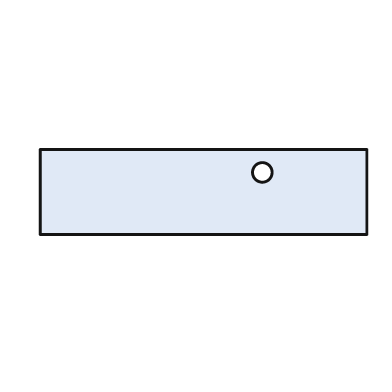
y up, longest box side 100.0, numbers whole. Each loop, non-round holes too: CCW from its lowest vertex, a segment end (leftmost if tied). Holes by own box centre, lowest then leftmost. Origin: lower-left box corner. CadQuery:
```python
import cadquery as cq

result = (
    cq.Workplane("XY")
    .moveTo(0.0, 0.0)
    .lineTo(100.0, 0.0)
    .lineTo(100.0, 26.0)
    .lineTo(0.0, 26.0)
    .close()
    .moveTo(68.0, 19.0)
    .circle(3.0)
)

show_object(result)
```